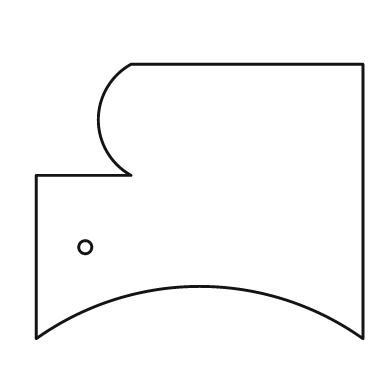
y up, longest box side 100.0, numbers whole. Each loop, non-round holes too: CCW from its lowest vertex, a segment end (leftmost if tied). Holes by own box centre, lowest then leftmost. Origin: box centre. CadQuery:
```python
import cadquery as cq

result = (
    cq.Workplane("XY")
    .moveTo(-50.0, -42.0)
    .threePointArc((0.0, -26.0), (50.0, -42.0))
    .lineTo(50.0, 42.0)
    .lineTo(-21.0, 42.0)
    .threePointArc((-31.0, 25.0), (-21.0, 8.0))
    .lineTo(-50.0, 8.0)
    .close()
    .moveTo(-35.0, -14.0)
    .circle(2.0)
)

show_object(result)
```